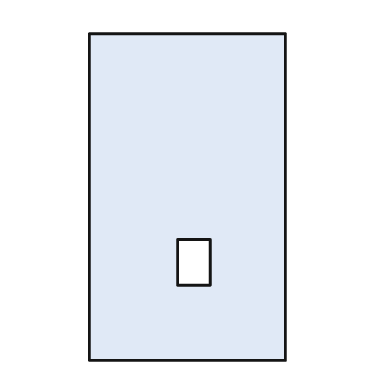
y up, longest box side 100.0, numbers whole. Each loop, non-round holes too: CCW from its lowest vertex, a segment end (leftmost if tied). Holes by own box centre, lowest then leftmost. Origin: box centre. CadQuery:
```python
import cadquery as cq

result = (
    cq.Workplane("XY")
    .moveTo(-30.0, -50.0)
    .lineTo(30.0, -50.0)
    .lineTo(30.0, 50.0)
    .lineTo(-30.0, 50.0)
    .close()
    .moveTo(-3.0, -27.0)
    .lineTo(7.0, -27.0)
    .lineTo(7.0, -13.0)
    .lineTo(-3.0, -13.0)
    .close()
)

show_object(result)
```